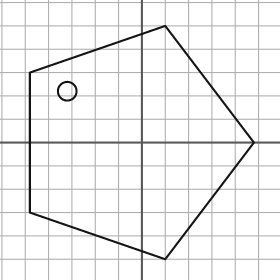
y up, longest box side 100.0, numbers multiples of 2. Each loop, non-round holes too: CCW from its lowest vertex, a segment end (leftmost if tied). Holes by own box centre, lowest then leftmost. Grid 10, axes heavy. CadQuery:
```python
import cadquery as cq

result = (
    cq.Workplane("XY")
    .moveTo(10.0, -50.0)
    .lineTo(48.0, 0.0)
    .lineTo(10.0, 50.0)
    .lineTo(-48.0, 30.0)
    .lineTo(-48.0, -30.0)
    .close()
    .moveTo(-32.0, 22.0)
    .circle(4.0)
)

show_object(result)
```